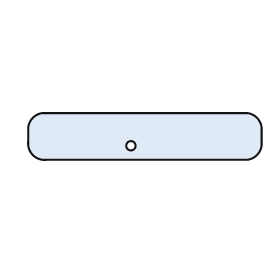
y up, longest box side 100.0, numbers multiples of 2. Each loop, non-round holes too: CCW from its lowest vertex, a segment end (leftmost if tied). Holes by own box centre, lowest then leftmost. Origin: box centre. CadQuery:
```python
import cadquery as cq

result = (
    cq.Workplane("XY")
    .moveTo(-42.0, -10.0)
    .lineTo(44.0, -10.0)
    .threePointArc((48.0, -8.0), (50.0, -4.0))
    .lineTo(50.0, 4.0)
    .threePointArc((48.0, 8.0), (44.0, 10.0))
    .lineTo(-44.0, 10.0)
    .threePointArc((-48.0, 8.0), (-50.0, 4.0))
    .lineTo(-50.0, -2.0)
    .threePointArc((-48.0, -8.0), (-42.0, -10.0))
    .close()
    .moveTo(-6.0, -4.0)
    .circle(2.0)
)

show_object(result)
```